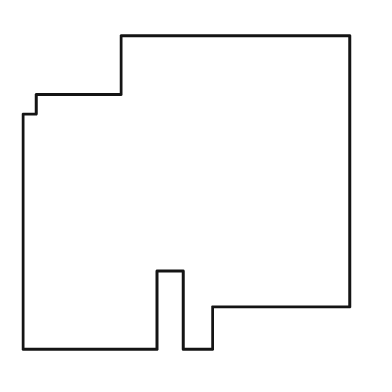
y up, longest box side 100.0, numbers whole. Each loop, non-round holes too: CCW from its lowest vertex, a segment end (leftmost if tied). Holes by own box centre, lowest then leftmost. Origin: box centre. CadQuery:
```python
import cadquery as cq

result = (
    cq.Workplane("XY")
    .moveTo(-50.0, -48.0)
    .lineTo(-9.0, -48.0)
    .lineTo(-9.0, -24.0)
    .lineTo(-1.0, -24.0)
    .lineTo(-1.0, -48.0)
    .lineTo(8.0, -48.0)
    .lineTo(8.0, -35.0)
    .lineTo(50.0, -35.0)
    .lineTo(50.0, 48.0)
    .lineTo(-20.0, 48.0)
    .lineTo(-20.0, 30.0)
    .lineTo(-46.0, 30.0)
    .lineTo(-46.0, 24.0)
    .lineTo(-50.0, 24.0)
    .close()
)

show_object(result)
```